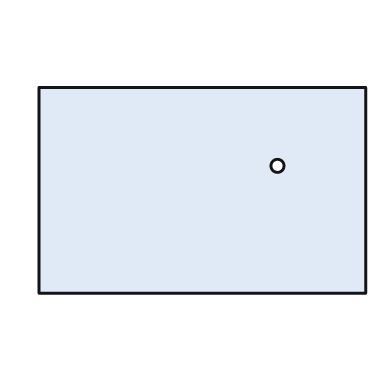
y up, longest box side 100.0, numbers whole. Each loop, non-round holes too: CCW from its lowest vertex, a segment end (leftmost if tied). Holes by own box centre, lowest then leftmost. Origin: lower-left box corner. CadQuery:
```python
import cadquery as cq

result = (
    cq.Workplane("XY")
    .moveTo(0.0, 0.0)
    .lineTo(100.0, 0.0)
    .lineTo(100.0, 63.0)
    .lineTo(0.0, 63.0)
    .close()
    .moveTo(73.0, 39.0)
    .circle(2.0)
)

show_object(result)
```